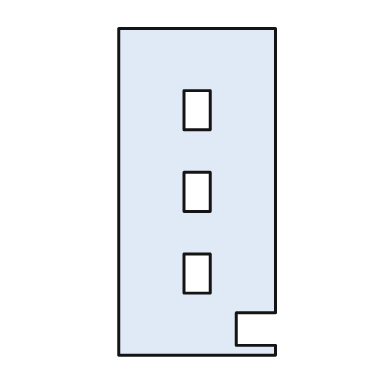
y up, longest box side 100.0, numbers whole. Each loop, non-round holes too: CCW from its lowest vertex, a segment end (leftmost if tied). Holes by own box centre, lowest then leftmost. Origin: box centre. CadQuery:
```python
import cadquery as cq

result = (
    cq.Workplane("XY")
    .moveTo(-24.0, -50.0)
    .lineTo(24.0, -50.0)
    .lineTo(24.0, -47.0)
    .lineTo(12.0, -47.0)
    .lineTo(12.0, -37.0)
    .lineTo(24.0, -37.0)
    .lineTo(24.0, 50.0)
    .lineTo(-24.0, 50.0)
    .close()
    .moveTo(-4.0, -31.0)
    .lineTo(4.0, -31.0)
    .lineTo(4.0, -19.0)
    .lineTo(-4.0, -19.0)
    .close()
    .moveTo(-4.0, -6.0)
    .lineTo(4.0, -6.0)
    .lineTo(4.0, 6.0)
    .lineTo(-4.0, 6.0)
    .close()
    .moveTo(-4.0, 19.0)
    .lineTo(4.0, 19.0)
    .lineTo(4.0, 31.0)
    .lineTo(-4.0, 31.0)
    .close()
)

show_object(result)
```